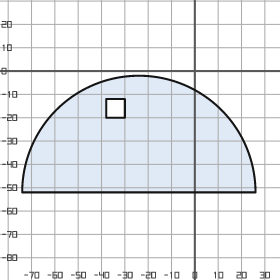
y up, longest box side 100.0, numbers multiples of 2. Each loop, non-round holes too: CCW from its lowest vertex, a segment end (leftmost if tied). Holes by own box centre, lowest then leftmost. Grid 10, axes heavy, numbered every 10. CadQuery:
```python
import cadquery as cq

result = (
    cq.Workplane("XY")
    .moveTo(-74.0, -52.0)
    .lineTo(26.0, -52.0)
    .threePointArc((-24.0, -2.0), (-74.0, -52.0))
    .close()
    .moveTo(-38.0, -20.0)
    .lineTo(-30.0, -20.0)
    .lineTo(-30.0, -12.0)
    .lineTo(-38.0, -12.0)
    .close()
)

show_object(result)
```